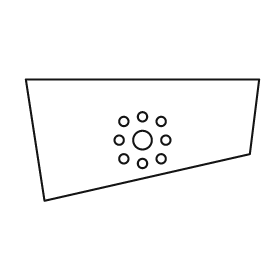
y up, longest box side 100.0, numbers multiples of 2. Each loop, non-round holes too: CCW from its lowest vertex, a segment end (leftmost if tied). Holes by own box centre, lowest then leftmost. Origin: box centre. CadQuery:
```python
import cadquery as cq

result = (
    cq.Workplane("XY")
    .moveTo(-42.0, -26.0)
    .lineTo(46.0, -6.0)
    .lineTo(50.0, 26.0)
    .lineTo(-50.0, 26.0)
    .close()
    .moveTo(0.0, -10.0)
    .circle(2.0)
    .moveTo(-8.0, -8.0)
    .circle(2.0)
    .moveTo(8.0, -8.0)
    .circle(2.0)
    .moveTo(-10.0, 0.0)
    .circle(2.0)
    .moveTo(0.0, 0.0)
    .circle(4.0)
    .moveTo(10.0, 0.0)
    .circle(2.0)
    .moveTo(-8.0, 8.0)
    .circle(2.0)
    .moveTo(8.0, 8.0)
    .circle(2.0)
    .moveTo(0.0, 10.0)
    .circle(2.0)
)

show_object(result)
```